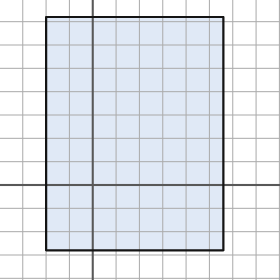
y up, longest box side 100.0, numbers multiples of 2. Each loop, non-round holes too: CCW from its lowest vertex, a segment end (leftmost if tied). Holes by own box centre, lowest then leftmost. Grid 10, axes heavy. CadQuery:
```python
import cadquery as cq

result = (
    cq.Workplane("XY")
    .moveTo(-20.0, -28.0)
    .lineTo(56.0, -28.0)
    .lineTo(56.0, 72.0)
    .lineTo(-20.0, 72.0)
    .close()
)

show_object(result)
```